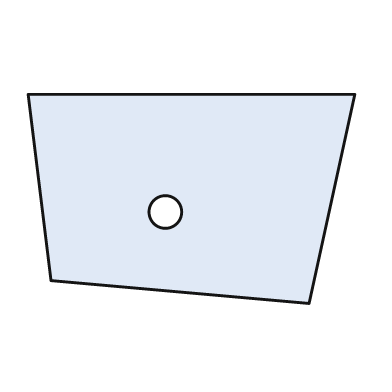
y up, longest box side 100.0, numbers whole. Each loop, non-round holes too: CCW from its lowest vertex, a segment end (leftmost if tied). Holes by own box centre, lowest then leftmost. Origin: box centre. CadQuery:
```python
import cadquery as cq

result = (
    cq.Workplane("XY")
    .moveTo(36.0, -32.0)
    .lineTo(50.0, 32.0)
    .lineTo(-50.0, 32.0)
    .lineTo(-43.0, -25.0)
    .close()
    .moveTo(-8.0, -4.0)
    .circle(5.0)
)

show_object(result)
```